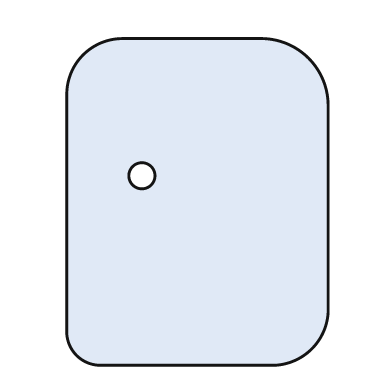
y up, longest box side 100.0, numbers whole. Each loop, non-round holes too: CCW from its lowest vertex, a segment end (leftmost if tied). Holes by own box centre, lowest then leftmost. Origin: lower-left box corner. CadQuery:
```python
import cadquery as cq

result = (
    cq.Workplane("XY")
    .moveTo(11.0, 0.0)
    .lineTo(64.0, 0.0)
    .threePointArc((75.0, 5.0), (80.0, 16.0))
    .lineTo(80.0, 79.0)
    .threePointArc((74.0, 94.0), (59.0, 100.0))
    .lineTo(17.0, 100.0)
    .threePointArc((5.0, 95.0), (0.0, 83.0))
    .lineTo(0.0, 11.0)
    .threePointArc((3.0, 3.0), (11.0, 0.0))
    .close()
    .moveTo(23.0, 58.0)
    .circle(4.0)
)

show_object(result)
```